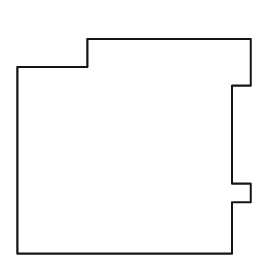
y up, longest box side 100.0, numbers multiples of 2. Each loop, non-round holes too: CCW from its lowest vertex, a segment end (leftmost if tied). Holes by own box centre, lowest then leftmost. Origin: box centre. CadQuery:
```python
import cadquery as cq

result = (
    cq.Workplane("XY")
    .moveTo(-50.0, -46.0)
    .lineTo(42.0, -46.0)
    .lineTo(42.0, -24.0)
    .lineTo(50.0, -24.0)
    .lineTo(50.0, -16.0)
    .lineTo(42.0, -16.0)
    .lineTo(42.0, 26.0)
    .lineTo(50.0, 26.0)
    .lineTo(50.0, 46.0)
    .lineTo(-20.0, 46.0)
    .lineTo(-20.0, 34.0)
    .lineTo(-50.0, 34.0)
    .close()
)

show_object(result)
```